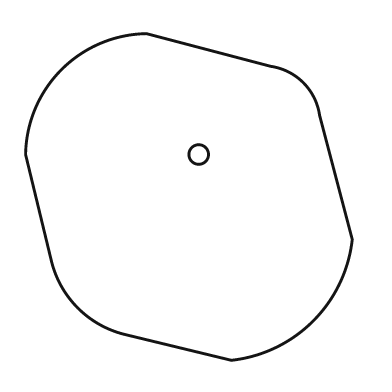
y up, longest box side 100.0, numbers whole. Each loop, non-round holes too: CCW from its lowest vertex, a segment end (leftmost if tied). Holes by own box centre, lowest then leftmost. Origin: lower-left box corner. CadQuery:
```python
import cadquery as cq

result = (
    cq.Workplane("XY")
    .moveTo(63.0, 0.0)
    .threePointArc((88.0, 12.0), (100.0, 37.0))
    .lineTo(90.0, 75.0)
    .threePointArc((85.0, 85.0), (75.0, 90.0))
    .lineTo(37.0, 100.0)
    .threePointArc((11.0, 89.0), (0.0, 63.0))
    .lineTo(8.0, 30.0)
    .threePointArc((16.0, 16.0), (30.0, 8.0))
    .close()
    .moveTo(53.0, 63.0)
    .circle(3.0)
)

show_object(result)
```